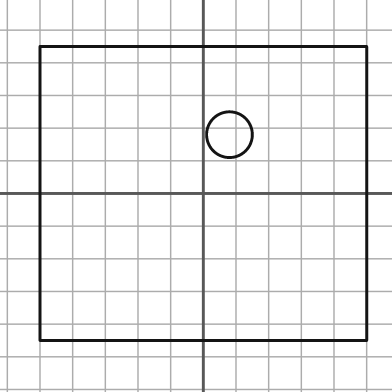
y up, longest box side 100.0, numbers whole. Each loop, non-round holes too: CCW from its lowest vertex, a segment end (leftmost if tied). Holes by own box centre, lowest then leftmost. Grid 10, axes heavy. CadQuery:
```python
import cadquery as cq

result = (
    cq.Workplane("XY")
    .moveTo(-50.0, -45.0)
    .lineTo(50.0, -45.0)
    .lineTo(50.0, 45.0)
    .lineTo(-50.0, 45.0)
    .close()
    .moveTo(8.0, 18.0)
    .circle(7.0)
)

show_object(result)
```